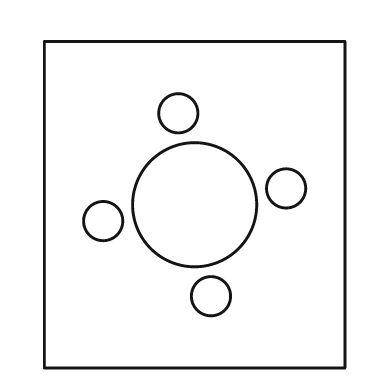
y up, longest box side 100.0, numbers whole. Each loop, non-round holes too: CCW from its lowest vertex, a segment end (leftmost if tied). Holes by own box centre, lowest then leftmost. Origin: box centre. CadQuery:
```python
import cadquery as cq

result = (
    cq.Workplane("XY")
    .moveTo(-46.0, -50.0)
    .lineTo(46.0, -50.0)
    .lineTo(46.0, 50.0)
    .lineTo(-46.0, 50.0)
    .close()
    .moveTo(5.0, -28.0)
    .circle(6.0)
    .moveTo(-28.0, -5.0)
    .circle(6.0)
    .moveTo(0.0, 0.0)
    .circle(19.0)
    .moveTo(28.0, 5.0)
    .circle(6.0)
    .moveTo(-5.0, 28.0)
    .circle(6.0)
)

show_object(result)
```